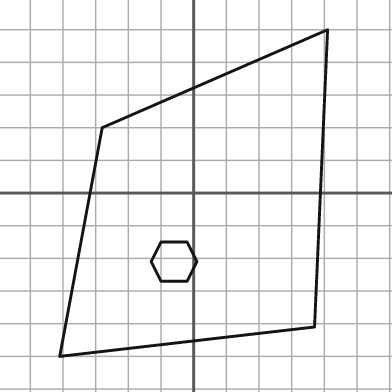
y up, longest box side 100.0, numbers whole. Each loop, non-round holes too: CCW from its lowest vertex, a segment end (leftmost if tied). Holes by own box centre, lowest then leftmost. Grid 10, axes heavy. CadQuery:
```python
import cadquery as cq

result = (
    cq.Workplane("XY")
    .moveTo(-41.0, -50.0)
    .lineTo(37.0, -41.0)
    .lineTo(41.0, 50.0)
    .lineTo(-28.0, 20.0)
    .close()
    .moveTo(-10.0, -27.0)
    .lineTo(-2.0, -27.0)
    .lineTo(1.0, -21.0)
    .lineTo(-2.0, -15.0)
    .lineTo(-10.0, -15.0)
    .lineTo(-13.0, -21.0)
    .close()
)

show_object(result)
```